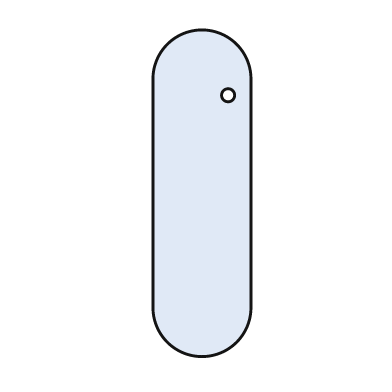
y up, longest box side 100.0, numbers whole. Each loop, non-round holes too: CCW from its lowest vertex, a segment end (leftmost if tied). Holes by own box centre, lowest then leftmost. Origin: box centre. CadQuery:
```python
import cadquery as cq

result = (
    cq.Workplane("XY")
    .moveTo(-15.0, -35.0)
    .threePointArc((0.0, -50.0), (15.0, -35.0))
    .lineTo(15.0, 35.0)
    .threePointArc((0.0, 50.0), (-15.0, 35.0))
    .close()
    .moveTo(8.0, 30.0)
    .circle(2.0)
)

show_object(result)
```